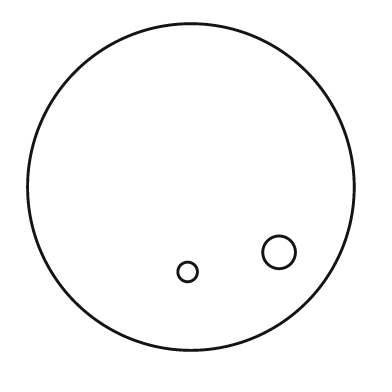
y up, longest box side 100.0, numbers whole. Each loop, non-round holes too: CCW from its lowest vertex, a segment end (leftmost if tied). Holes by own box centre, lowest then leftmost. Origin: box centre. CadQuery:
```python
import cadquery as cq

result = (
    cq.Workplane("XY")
    .moveTo(0.0, 0.0)
    .circle(50.0)
    .moveTo(-1.0, -26.0)
    .circle(3.0)
    .moveTo(27.0, -20.0)
    .circle(5.0)
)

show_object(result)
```